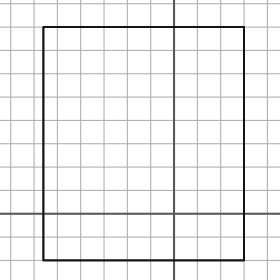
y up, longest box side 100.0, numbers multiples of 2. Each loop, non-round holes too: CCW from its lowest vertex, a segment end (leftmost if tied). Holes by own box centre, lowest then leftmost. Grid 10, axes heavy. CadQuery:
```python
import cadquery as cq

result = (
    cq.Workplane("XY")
    .moveTo(-56.0, -20.0)
    .lineTo(30.0, -20.0)
    .lineTo(30.0, 80.0)
    .lineTo(-56.0, 80.0)
    .close()
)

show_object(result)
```